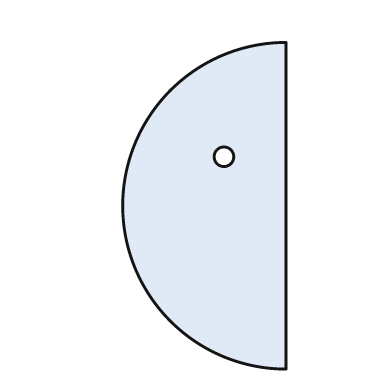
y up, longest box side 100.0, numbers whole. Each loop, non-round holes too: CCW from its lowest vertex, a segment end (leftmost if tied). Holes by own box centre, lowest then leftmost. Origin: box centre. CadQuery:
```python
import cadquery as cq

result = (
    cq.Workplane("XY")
    .moveTo(25.0, -50.0)
    .lineTo(25.0, 50.0)
    .threePointArc((-25.0, 0.0), (25.0, -50.0))
    .close()
    .moveTo(6.0, 15.0)
    .circle(3.0)
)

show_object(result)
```